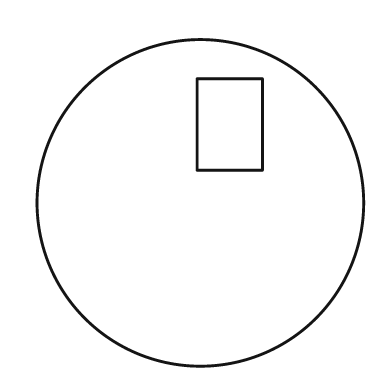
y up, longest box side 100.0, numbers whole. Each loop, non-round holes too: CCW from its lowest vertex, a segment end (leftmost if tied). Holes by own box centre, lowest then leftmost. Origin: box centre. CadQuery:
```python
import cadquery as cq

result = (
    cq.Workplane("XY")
    .moveTo(0.0, 0.0)
    .circle(50.0)
    .moveTo(-1.0, 10.0)
    .lineTo(19.0, 10.0)
    .lineTo(19.0, 38.0)
    .lineTo(-1.0, 38.0)
    .close()
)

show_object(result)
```